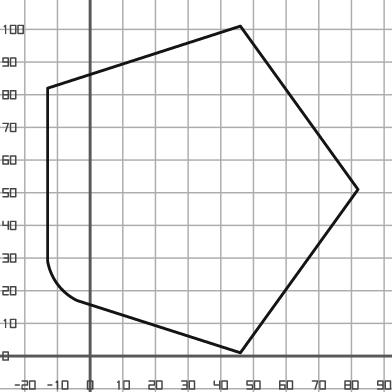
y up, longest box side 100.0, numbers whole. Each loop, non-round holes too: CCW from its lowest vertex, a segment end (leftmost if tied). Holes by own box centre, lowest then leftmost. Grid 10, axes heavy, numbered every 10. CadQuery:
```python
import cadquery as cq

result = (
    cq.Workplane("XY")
    .moveTo(46.0, 1.0)
    .lineTo(82.0, 51.0)
    .lineTo(46.0, 101.0)
    .lineTo(-13.0, 82.0)
    .lineTo(-13.0, 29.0)
    .threePointArc((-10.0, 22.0), (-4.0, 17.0))
    .close()
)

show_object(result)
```